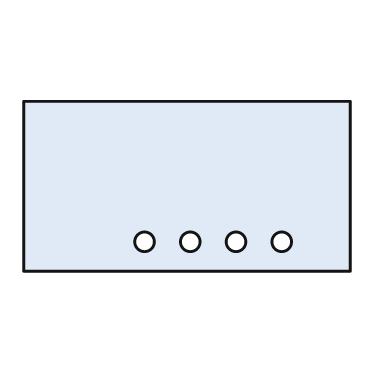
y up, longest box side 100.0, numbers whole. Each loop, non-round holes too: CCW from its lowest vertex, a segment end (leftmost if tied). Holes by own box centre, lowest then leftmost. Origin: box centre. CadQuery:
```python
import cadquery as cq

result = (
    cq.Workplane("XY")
    .moveTo(-50.0, -26.0)
    .lineTo(50.0, -26.0)
    .lineTo(50.0, 26.0)
    .lineTo(-50.0, 26.0)
    .close()
    .moveTo(-13.0, -17.0)
    .circle(3.0)
    .moveTo(1.0, -17.0)
    .circle(3.0)
    .moveTo(15.0, -17.0)
    .circle(3.0)
    .moveTo(29.0, -17.0)
    .circle(3.0)
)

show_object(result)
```